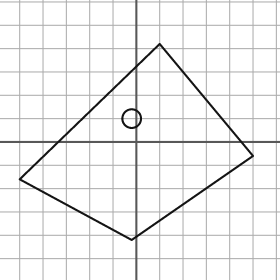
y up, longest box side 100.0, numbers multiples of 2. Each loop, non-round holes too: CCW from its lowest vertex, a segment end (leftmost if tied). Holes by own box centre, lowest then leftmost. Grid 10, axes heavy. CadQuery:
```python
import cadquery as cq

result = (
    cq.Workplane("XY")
    .moveTo(-2.0, -42.0)
    .lineTo(50.0, -6.0)
    .lineTo(10.0, 42.0)
    .lineTo(-50.0, -16.0)
    .close()
    .moveTo(-2.0, 10.0)
    .circle(4.0)
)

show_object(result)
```